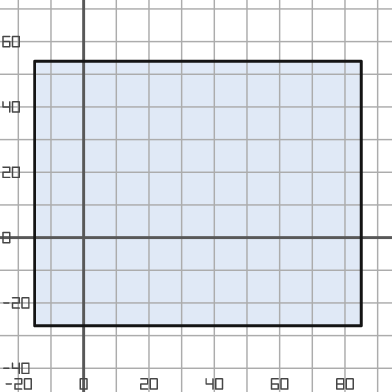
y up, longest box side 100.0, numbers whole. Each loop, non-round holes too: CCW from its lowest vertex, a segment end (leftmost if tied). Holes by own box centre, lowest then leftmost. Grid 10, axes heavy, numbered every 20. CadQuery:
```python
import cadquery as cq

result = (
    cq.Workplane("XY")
    .moveTo(-15.0, -27.0)
    .lineTo(85.0, -27.0)
    .lineTo(85.0, 54.0)
    .lineTo(-15.0, 54.0)
    .close()
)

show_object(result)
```